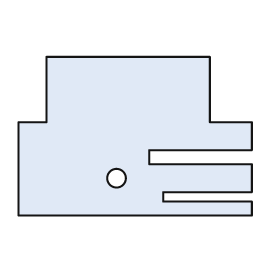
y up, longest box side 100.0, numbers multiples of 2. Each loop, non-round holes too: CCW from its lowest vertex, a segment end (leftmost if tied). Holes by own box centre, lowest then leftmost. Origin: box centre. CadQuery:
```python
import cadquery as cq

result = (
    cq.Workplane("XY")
    .moveTo(-50.0, -34.0)
    .lineTo(50.0, -34.0)
    .lineTo(50.0, -28.0)
    .lineTo(12.0, -28.0)
    .lineTo(12.0, -24.0)
    .lineTo(50.0, -24.0)
    .lineTo(50.0, -12.0)
    .lineTo(6.0, -12.0)
    .lineTo(6.0, -6.0)
    .lineTo(50.0, -6.0)
    .lineTo(50.0, 6.0)
    .lineTo(32.0, 6.0)
    .lineTo(32.0, 34.0)
    .lineTo(-38.0, 34.0)
    .lineTo(-38.0, 6.0)
    .lineTo(-50.0, 6.0)
    .close()
    .moveTo(-8.0, -18.0)
    .circle(4.0)
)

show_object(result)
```